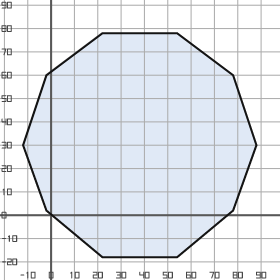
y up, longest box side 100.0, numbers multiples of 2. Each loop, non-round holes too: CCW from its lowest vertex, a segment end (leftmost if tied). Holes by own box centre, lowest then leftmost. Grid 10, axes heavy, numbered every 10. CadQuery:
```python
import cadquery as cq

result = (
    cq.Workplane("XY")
    .moveTo(22.0, -18.0)
    .lineTo(54.0, -18.0)
    .lineTo(78.0, 2.0)
    .lineTo(88.0, 30.0)
    .lineTo(78.0, 60.0)
    .lineTo(54.0, 78.0)
    .lineTo(22.0, 78.0)
    .lineTo(-2.0, 60.0)
    .lineTo(-12.0, 30.0)
    .lineTo(-2.0, 2.0)
    .close()
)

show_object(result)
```